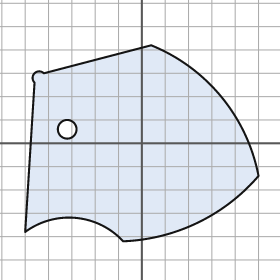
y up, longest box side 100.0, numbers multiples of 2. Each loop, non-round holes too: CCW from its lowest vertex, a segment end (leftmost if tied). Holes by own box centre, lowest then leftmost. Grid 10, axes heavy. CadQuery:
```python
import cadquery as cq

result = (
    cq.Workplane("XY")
    .moveTo(-8.0, -42.0)
    .threePointArc((24.0, -34.0), (50.0, -14.0))
    .threePointArc((34.0, 20.0), (4.0, 42.0))
    .lineTo(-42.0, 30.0)
    .threePointArc((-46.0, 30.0), (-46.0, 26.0))
    .lineTo(-50.0, -38.0)
    .threePointArc((-28.0, -32.0), (-8.0, -42.0))
    .close()
    .moveTo(-32.0, 6.0)
    .circle(4.0)
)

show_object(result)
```